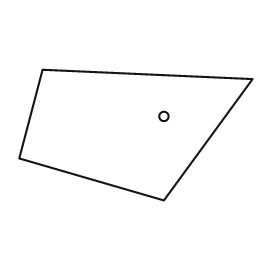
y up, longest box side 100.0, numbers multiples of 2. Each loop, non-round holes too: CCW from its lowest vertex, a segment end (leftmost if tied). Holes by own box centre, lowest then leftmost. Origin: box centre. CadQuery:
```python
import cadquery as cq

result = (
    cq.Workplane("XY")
    .moveTo(12.0, -28.0)
    .lineTo(50.0, 24.0)
    .lineTo(-40.0, 28.0)
    .lineTo(-50.0, -10.0)
    .close()
    .moveTo(12.0, 8.0)
    .circle(2.0)
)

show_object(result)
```